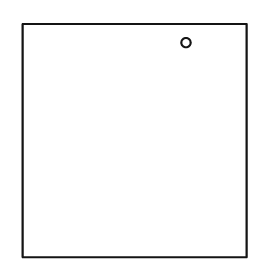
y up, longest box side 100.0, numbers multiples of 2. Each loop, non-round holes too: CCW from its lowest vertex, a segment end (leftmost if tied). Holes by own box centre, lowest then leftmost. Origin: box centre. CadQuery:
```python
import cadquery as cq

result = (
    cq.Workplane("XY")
    .moveTo(-48.0, -50.0)
    .lineTo(48.0, -50.0)
    .lineTo(48.0, 50.0)
    .lineTo(-48.0, 50.0)
    .close()
    .moveTo(22.0, 42.0)
    .circle(2.0)
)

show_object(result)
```